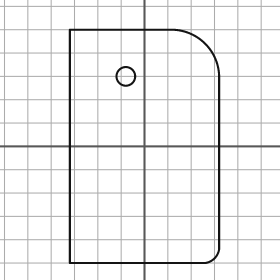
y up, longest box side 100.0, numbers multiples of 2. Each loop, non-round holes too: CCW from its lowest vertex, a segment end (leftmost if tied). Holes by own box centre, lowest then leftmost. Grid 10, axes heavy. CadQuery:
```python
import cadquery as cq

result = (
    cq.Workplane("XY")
    .moveTo(-32.0, -50.0)
    .lineTo(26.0, -50.0)
    .threePointArc((30.0, -48.0), (32.0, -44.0))
    .lineTo(32.0, 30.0)
    .threePointArc((26.0, 44.0), (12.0, 50.0))
    .lineTo(-32.0, 50.0)
    .close()
    .moveTo(-8.0, 30.0)
    .circle(4.0)
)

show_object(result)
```